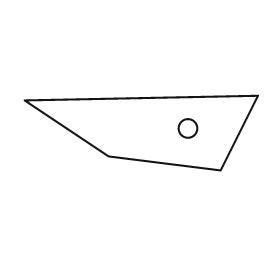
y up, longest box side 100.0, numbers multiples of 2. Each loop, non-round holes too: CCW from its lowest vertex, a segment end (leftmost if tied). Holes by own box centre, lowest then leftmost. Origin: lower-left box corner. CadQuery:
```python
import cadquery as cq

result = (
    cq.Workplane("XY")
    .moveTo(84.0, 0.0)
    .lineTo(100.0, 32.0)
    .lineTo(0.0, 30.0)
    .lineTo(36.0, 6.0)
    .close()
    .moveTo(70.0, 18.0)
    .circle(4.0)
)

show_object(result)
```